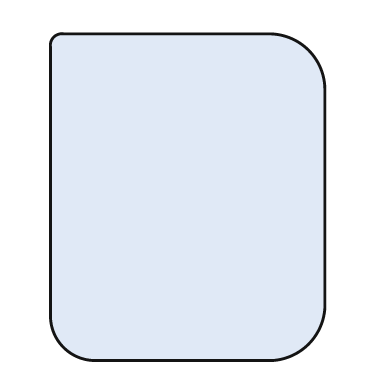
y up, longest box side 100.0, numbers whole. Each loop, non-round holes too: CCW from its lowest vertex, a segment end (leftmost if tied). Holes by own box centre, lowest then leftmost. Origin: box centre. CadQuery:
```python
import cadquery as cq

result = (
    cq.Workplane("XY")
    .moveTo(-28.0, -50.0)
    .lineTo(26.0, -50.0)
    .threePointArc((37.0, -45.0), (42.0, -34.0))
    .lineTo(42.0, 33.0)
    .threePointArc((37.0, 45.0), (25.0, 50.0))
    .lineTo(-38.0, 50.0)
    .threePointArc((-41.0, 49.0), (-42.0, 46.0))
    .lineTo(-42.0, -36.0)
    .threePointArc((-38.0, -46.0), (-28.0, -50.0))
    .close()
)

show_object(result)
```